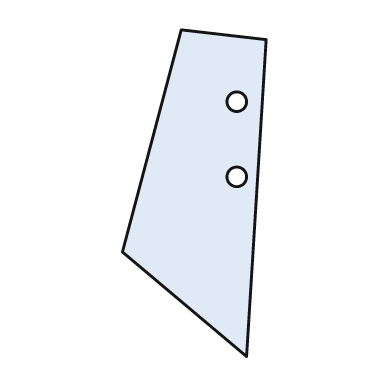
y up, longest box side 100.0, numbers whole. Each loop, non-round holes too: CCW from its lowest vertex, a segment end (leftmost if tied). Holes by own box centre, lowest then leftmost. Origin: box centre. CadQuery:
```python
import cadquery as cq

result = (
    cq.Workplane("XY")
    .moveTo(16.0, -50.0)
    .lineTo(22.0, 47.0)
    .lineTo(-4.0, 50.0)
    .lineTo(-22.0, -18.0)
    .close()
    .moveTo(13.0, 5.0)
    .circle(3.0)
    .moveTo(13.0, 28.0)
    .circle(3.0)
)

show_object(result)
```